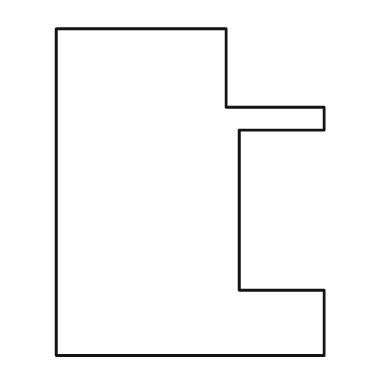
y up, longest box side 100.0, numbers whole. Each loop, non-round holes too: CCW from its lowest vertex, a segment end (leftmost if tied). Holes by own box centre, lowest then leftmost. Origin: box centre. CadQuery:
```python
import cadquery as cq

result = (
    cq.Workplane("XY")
    .moveTo(-41.0, -50.0)
    .lineTo(41.0, -50.0)
    .lineTo(41.0, -30.0)
    .lineTo(15.0, -30.0)
    .lineTo(15.0, 19.0)
    .lineTo(41.0, 19.0)
    .lineTo(41.0, 26.0)
    .lineTo(11.0, 26.0)
    .lineTo(11.0, 50.0)
    .lineTo(-41.0, 50.0)
    .close()
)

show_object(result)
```